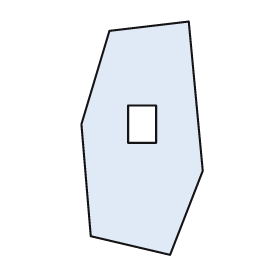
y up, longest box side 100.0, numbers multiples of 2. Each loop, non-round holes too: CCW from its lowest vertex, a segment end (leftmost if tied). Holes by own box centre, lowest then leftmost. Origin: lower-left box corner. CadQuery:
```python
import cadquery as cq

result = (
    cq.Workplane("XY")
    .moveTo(38.0, 0.0)
    .lineTo(52.0, 36.0)
    .lineTo(46.0, 100.0)
    .lineTo(12.0, 96.0)
    .lineTo(0.0, 56.0)
    .lineTo(4.0, 8.0)
    .close()
    .moveTo(20.0, 48.0)
    .lineTo(32.0, 48.0)
    .lineTo(32.0, 64.0)
    .lineTo(20.0, 64.0)
    .close()
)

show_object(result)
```